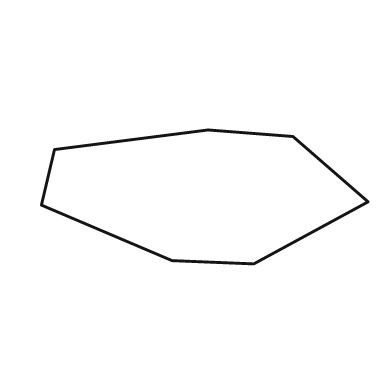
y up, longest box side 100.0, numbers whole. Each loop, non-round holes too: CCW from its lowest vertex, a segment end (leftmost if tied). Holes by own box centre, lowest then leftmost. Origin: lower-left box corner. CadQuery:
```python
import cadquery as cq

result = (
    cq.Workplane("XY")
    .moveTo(65.0, 0.0)
    .lineTo(100.0, 19.0)
    .lineTo(77.0, 39.0)
    .lineTo(51.0, 41.0)
    .lineTo(4.0, 35.0)
    .lineTo(0.0, 18.0)
    .lineTo(40.0, 1.0)
    .close()
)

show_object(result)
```